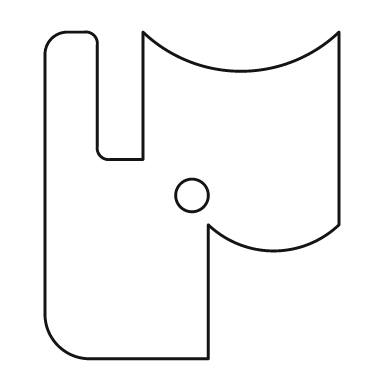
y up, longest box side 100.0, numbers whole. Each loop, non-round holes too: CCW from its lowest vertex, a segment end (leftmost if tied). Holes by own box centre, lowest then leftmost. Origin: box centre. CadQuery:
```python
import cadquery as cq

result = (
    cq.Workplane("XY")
    .moveTo(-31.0, -50.0)
    .lineTo(5.0, -50.0)
    .lineTo(5.0, -9.0)
    .threePointArc((25.0, -17.0), (45.0, -9.0))
    .lineTo(45.0, 50.0)
    .threePointArc((15.0, 38.0), (-15.0, 50.0))
    .lineTo(-15.0, 11.0)
    .lineTo(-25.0, 11.0)
    .threePointArc((-28.0, 12.0), (-29.0, 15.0))
    .lineTo(-29.0, 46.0)
    .threePointArc((-30.0, 49.0), (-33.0, 50.0))
    .lineTo(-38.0, 50.0)
    .threePointArc((-43.0, 48.0), (-45.0, 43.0))
    .lineTo(-45.0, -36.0)
    .threePointArc((-41.0, -46.0), (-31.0, -50.0))
    .close()
    .moveTo(0.0, 0.0)
    .circle(5.0)
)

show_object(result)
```